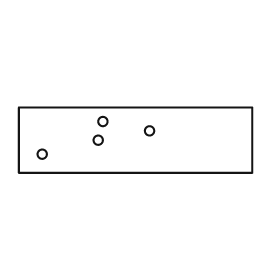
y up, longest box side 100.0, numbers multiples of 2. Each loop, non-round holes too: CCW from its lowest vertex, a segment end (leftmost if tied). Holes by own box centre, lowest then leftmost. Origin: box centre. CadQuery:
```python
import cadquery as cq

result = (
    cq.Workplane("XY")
    .moveTo(-50.0, -14.0)
    .lineTo(50.0, -14.0)
    .lineTo(50.0, 14.0)
    .lineTo(-50.0, 14.0)
    .close()
    .moveTo(-40.0, -6.0)
    .circle(2.0)
    .moveTo(-16.0, 0.0)
    .circle(2.0)
    .moveTo(6.0, 4.0)
    .circle(2.0)
    .moveTo(-14.0, 8.0)
    .circle(2.0)
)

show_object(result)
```